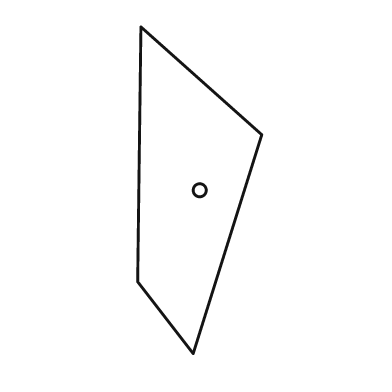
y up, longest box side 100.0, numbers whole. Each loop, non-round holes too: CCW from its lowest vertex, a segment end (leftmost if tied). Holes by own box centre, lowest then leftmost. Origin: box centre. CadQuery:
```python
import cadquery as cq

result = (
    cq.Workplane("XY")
    .moveTo(-2.0, -50.0)
    .lineTo(19.0, 17.0)
    .lineTo(-18.0, 50.0)
    .lineTo(-19.0, -28.0)
    .close()
    .moveTo(0.0, 0.0)
    .circle(2.0)
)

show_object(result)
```